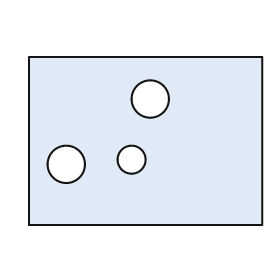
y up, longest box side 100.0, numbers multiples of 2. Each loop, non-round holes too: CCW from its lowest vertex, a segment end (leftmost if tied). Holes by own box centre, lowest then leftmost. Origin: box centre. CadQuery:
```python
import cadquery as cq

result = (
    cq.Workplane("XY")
    .moveTo(-50.0, -36.0)
    .lineTo(50.0, -36.0)
    .lineTo(50.0, 36.0)
    .lineTo(-50.0, 36.0)
    .close()
    .moveTo(-34.0, -10.0)
    .circle(8.0)
    .moveTo(-6.0, -8.0)
    .circle(6.0)
    .moveTo(2.0, 18.0)
    .circle(8.0)
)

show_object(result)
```